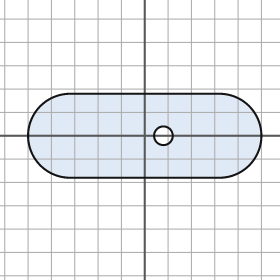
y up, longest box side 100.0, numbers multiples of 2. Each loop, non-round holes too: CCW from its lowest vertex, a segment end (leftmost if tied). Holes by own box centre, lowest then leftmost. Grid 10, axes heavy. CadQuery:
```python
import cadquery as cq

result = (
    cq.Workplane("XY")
    .moveTo(-32.0, -18.0)
    .lineTo(32.0, -18.0)
    .threePointArc((50.0, 0.0), (32.0, 18.0))
    .lineTo(-32.0, 18.0)
    .threePointArc((-50.0, 0.0), (-32.0, -18.0))
    .close()
    .moveTo(8.0, 0.0)
    .circle(4.0)
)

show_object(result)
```